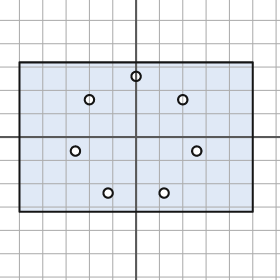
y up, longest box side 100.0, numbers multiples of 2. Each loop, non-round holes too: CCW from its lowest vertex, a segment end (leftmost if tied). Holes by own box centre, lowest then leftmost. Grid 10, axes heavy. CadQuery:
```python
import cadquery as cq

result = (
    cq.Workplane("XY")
    .moveTo(-50.0, -32.0)
    .lineTo(50.0, -32.0)
    .lineTo(50.0, 32.0)
    .lineTo(-50.0, 32.0)
    .close()
    .moveTo(-12.0, -24.0)
    .circle(2.0)
    .moveTo(12.0, -24.0)
    .circle(2.0)
    .moveTo(-26.0, -6.0)
    .circle(2.0)
    .moveTo(26.0, -6.0)
    .circle(2.0)
    .moveTo(-20.0, 16.0)
    .circle(2.0)
    .moveTo(20.0, 16.0)
    .circle(2.0)
    .moveTo(0.0, 26.0)
    .circle(2.0)
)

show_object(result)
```